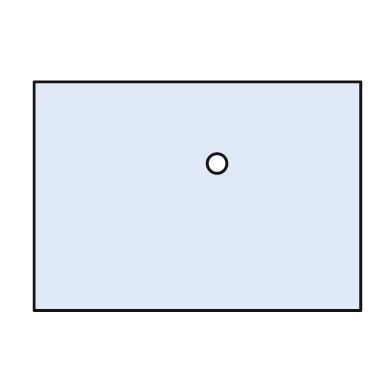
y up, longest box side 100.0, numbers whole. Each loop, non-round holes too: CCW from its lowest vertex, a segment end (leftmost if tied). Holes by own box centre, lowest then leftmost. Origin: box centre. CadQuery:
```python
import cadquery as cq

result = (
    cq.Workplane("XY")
    .moveTo(-50.0, -35.0)
    .lineTo(50.0, -35.0)
    .lineTo(50.0, 35.0)
    .lineTo(-50.0, 35.0)
    .close()
    .moveTo(6.0, 10.0)
    .circle(3.0)
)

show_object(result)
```